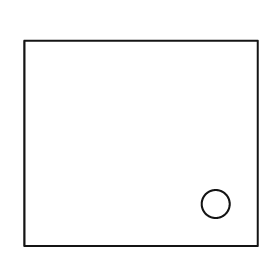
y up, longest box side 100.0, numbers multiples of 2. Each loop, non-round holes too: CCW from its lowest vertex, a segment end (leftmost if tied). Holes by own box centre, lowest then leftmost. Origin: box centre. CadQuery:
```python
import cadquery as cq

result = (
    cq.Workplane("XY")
    .moveTo(-50.0, -44.0)
    .lineTo(50.0, -44.0)
    .lineTo(50.0, 44.0)
    .lineTo(-50.0, 44.0)
    .close()
    .moveTo(32.0, -26.0)
    .circle(6.0)
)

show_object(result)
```